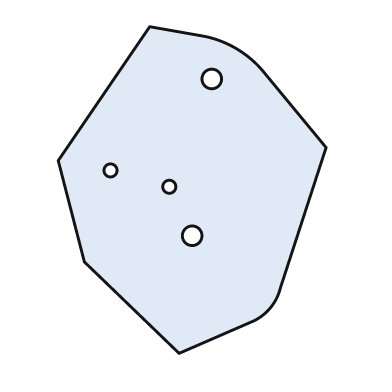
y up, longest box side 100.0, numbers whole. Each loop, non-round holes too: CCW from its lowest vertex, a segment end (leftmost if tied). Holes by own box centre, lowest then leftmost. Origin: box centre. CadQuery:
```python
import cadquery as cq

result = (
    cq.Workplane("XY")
    .moveTo(-4.0, -50.0)
    .lineTo(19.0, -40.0)
    .threePointArc((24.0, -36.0), (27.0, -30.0))
    .lineTo(41.0, 13.0)
    .lineTo(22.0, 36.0)
    .threePointArc((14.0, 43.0), (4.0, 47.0))
    .lineTo(-13.0, 50.0)
    .lineTo(-41.0, 9.0)
    .lineTo(-33.0, -22.0)
    .close()
    .moveTo(0.0, -14.0)
    .circle(3.0)
    .moveTo(-7.0, 1.0)
    .circle(2.0)
    .moveTo(-25.0, 6.0)
    .circle(2.0)
    .moveTo(6.0, 34.0)
    .circle(3.0)
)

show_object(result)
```